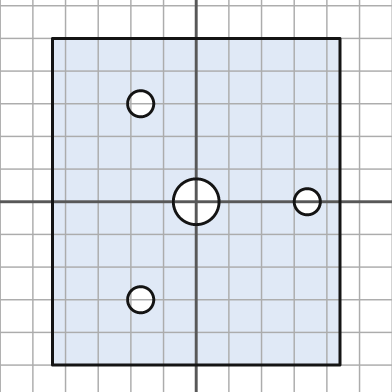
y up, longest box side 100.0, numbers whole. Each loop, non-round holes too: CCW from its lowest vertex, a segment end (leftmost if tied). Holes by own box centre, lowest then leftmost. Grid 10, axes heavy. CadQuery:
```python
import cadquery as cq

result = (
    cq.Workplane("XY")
    .moveTo(-44.0, -50.0)
    .lineTo(44.0, -50.0)
    .lineTo(44.0, 50.0)
    .lineTo(-44.0, 50.0)
    .close()
    .moveTo(-17.0, -30.0)
    .circle(4.0)
    .moveTo(0.0, 0.0)
    .circle(7.0)
    .moveTo(34.0, 0.0)
    .circle(4.0)
    .moveTo(-17.0, 30.0)
    .circle(4.0)
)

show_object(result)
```